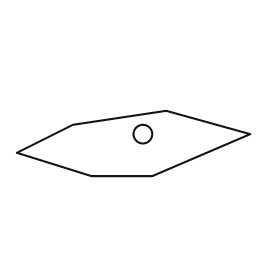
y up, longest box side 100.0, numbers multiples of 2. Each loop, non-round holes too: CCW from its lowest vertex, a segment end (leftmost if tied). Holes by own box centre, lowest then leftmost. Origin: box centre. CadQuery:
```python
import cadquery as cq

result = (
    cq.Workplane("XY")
    .moveTo(-18.0, -14.0)
    .lineTo(8.0, -14.0)
    .lineTo(50.0, 4.0)
    .lineTo(14.0, 14.0)
    .lineTo(-26.0, 8.0)
    .lineTo(-50.0, -4.0)
    .close()
    .moveTo(4.0, 4.0)
    .circle(4.0)
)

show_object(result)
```